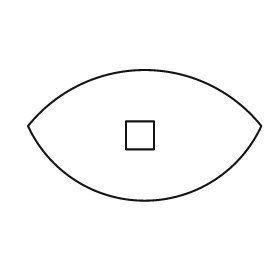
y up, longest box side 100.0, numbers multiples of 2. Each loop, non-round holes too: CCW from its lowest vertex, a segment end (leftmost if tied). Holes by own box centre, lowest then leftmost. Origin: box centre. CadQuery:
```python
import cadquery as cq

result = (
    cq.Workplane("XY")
    .moveTo(-50.0, 4.0)
    .threePointArc((0.0, -28.0), (50.0, 4.0))
    .threePointArc((0.0, 28.0), (-50.0, 4.0))
    .close()
    .moveTo(-8.0, -6.0)
    .lineTo(4.0, -6.0)
    .lineTo(4.0, 6.0)
    .lineTo(-8.0, 6.0)
    .close()
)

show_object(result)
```